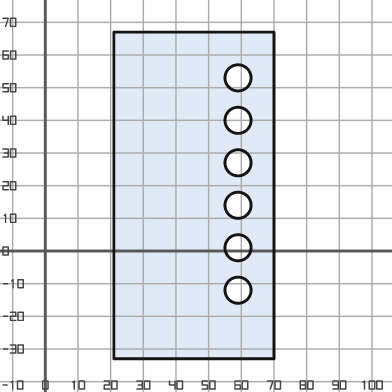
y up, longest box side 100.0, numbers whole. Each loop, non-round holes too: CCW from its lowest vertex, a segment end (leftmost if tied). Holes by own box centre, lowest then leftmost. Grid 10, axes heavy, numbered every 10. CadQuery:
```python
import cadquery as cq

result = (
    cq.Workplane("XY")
    .moveTo(21.0, -33.0)
    .lineTo(70.0, -33.0)
    .lineTo(70.0, 67.0)
    .lineTo(21.0, 67.0)
    .close()
    .moveTo(59.0, -12.0)
    .circle(4.0)
    .moveTo(59.0, 1.0)
    .circle(4.0)
    .moveTo(59.0, 14.0)
    .circle(4.0)
    .moveTo(59.0, 27.0)
    .circle(4.0)
    .moveTo(59.0, 40.0)
    .circle(4.0)
    .moveTo(59.0, 53.0)
    .circle(4.0)
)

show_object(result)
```